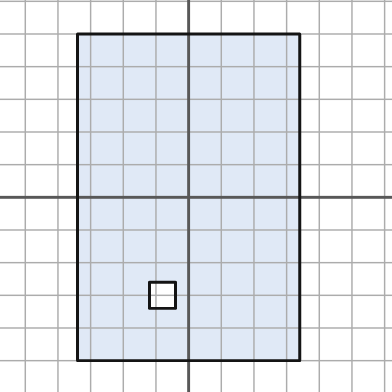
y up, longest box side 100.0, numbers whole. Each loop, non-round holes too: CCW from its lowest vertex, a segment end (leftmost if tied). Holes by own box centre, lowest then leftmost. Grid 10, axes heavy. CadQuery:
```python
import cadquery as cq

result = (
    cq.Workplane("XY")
    .moveTo(-34.0, -50.0)
    .lineTo(34.0, -50.0)
    .lineTo(34.0, 50.0)
    .lineTo(-34.0, 50.0)
    .close()
    .moveTo(-12.0, -34.0)
    .lineTo(-4.0, -34.0)
    .lineTo(-4.0, -26.0)
    .lineTo(-12.0, -26.0)
    .close()
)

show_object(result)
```